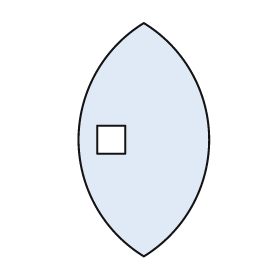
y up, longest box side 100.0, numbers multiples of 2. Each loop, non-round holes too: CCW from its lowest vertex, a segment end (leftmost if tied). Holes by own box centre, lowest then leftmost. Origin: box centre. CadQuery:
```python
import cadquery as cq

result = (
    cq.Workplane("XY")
    .moveTo(0.0, -50.0)
    .threePointArc((28.0, 0.0), (0.0, 50.0))
    .threePointArc((-28.0, 0.0), (0.0, -50.0))
    .close()
    .moveTo(-20.0, -6.0)
    .lineTo(-8.0, -6.0)
    .lineTo(-8.0, 6.0)
    .lineTo(-20.0, 6.0)
    .close()
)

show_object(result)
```